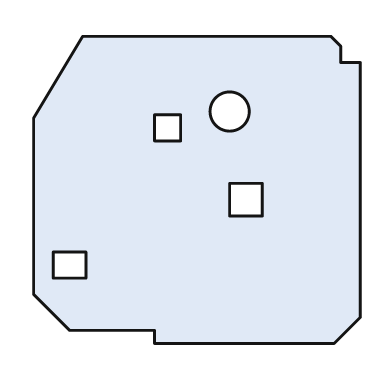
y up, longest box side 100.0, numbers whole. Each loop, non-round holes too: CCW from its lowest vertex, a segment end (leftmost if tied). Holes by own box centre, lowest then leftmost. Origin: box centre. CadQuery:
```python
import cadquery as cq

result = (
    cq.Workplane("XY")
    .moveTo(-13.0, -47.0)
    .lineTo(42.0, -47.0)
    .lineTo(50.0, -39.0)
    .lineTo(50.0, 39.0)
    .lineTo(44.0, 39.0)
    .lineTo(44.0, 44.0)
    .lineTo(41.0, 47.0)
    .lineTo(-35.0, 47.0)
    .lineTo(-50.0, 22.0)
    .lineTo(-50.0, -32.0)
    .lineTo(-39.0, -43.0)
    .lineTo(-13.0, -43.0)
    .close()
    .moveTo(-44.0, -27.0)
    .lineTo(-34.0, -27.0)
    .lineTo(-34.0, -19.0)
    .lineTo(-44.0, -19.0)
    .close()
    .moveTo(10.0, -8.0)
    .lineTo(20.0, -8.0)
    .lineTo(20.0, 2.0)
    .lineTo(10.0, 2.0)
    .close()
    .moveTo(-13.0, 15.0)
    .lineTo(-5.0, 15.0)
    .lineTo(-5.0, 23.0)
    .lineTo(-13.0, 23.0)
    .close()
    .moveTo(10.0, 24.0)
    .circle(6.0)
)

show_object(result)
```